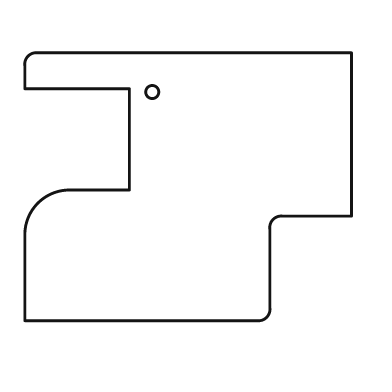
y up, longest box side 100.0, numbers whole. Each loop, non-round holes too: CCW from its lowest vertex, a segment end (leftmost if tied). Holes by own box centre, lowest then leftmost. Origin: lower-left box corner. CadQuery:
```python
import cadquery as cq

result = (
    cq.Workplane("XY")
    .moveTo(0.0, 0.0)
    .lineTo(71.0, 0.0)
    .threePointArc((74.0, 1.0), (75.0, 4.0))
    .lineTo(75.0, 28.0)
    .threePointArc((76.0, 31.0), (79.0, 32.0))
    .lineTo(100.0, 32.0)
    .lineTo(100.0, 82.0)
    .lineTo(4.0, 82.0)
    .threePointArc((1.0, 81.0), (0.0, 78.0))
    .lineTo(0.0, 71.0)
    .lineTo(32.0, 71.0)
    .lineTo(32.0, 40.0)
    .lineTo(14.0, 40.0)
    .threePointArc((4.0, 36.0), (0.0, 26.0))
    .close()
    .moveTo(39.0, 70.0)
    .circle(2.0)
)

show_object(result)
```